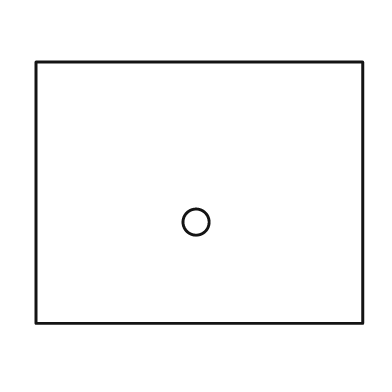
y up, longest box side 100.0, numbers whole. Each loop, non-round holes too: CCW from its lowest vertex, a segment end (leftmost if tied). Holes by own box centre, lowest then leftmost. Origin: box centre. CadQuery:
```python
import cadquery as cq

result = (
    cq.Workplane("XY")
    .moveTo(-50.0, -40.0)
    .lineTo(50.0, -40.0)
    .lineTo(50.0, 40.0)
    .lineTo(-50.0, 40.0)
    .close()
    .moveTo(-1.0, -9.0)
    .circle(4.0)
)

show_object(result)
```